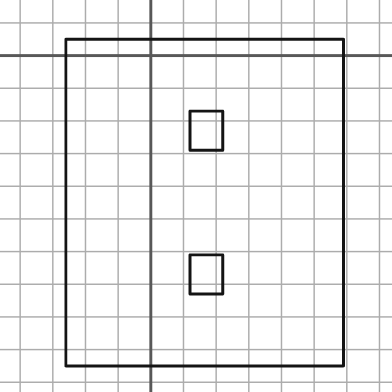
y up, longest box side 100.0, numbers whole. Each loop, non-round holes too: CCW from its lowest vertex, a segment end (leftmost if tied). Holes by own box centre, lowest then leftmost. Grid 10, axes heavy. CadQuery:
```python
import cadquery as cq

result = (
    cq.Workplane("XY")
    .moveTo(-26.0, -95.0)
    .lineTo(59.0, -95.0)
    .lineTo(59.0, 5.0)
    .lineTo(-26.0, 5.0)
    .close()
    .moveTo(12.0, -73.0)
    .lineTo(22.0, -73.0)
    .lineTo(22.0, -61.0)
    .lineTo(12.0, -61.0)
    .close()
    .moveTo(12.0, -29.0)
    .lineTo(22.0, -29.0)
    .lineTo(22.0, -17.0)
    .lineTo(12.0, -17.0)
    .close()
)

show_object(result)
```